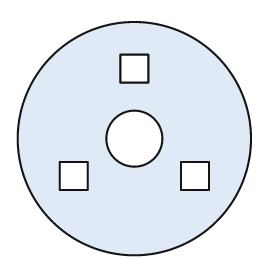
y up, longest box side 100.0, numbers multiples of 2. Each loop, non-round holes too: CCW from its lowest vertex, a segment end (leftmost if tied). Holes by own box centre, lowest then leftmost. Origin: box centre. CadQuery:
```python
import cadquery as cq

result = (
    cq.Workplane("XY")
    .moveTo(0.0, 0.0)
    .circle(50.0)
    .moveTo(-32.0, -22.0)
    .lineTo(-20.0, -22.0)
    .lineTo(-20.0, -10.0)
    .lineTo(-32.0, -10.0)
    .close()
    .moveTo(20.0, -22.0)
    .lineTo(32.0, -22.0)
    .lineTo(32.0, -10.0)
    .lineTo(20.0, -10.0)
    .close()
    .moveTo(0.0, 0.0)
    .circle(12.0)
    .moveTo(-6.0, 24.0)
    .lineTo(6.0, 24.0)
    .lineTo(6.0, 36.0)
    .lineTo(-6.0, 36.0)
    .close()
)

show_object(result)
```